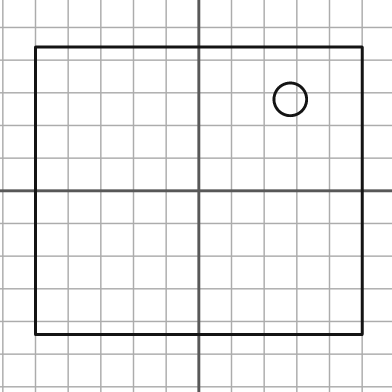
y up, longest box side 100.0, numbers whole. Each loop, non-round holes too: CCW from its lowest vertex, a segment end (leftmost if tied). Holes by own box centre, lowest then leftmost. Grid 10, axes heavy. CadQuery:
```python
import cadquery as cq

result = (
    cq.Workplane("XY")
    .moveTo(-50.0, -44.0)
    .lineTo(50.0, -44.0)
    .lineTo(50.0, 44.0)
    .lineTo(-50.0, 44.0)
    .close()
    .moveTo(28.0, 28.0)
    .circle(5.0)
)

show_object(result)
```